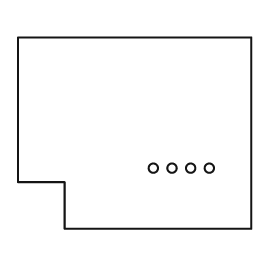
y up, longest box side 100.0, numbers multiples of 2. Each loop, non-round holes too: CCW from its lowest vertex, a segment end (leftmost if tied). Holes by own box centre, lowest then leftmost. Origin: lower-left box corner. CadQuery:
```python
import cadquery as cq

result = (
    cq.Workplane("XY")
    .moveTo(20.0, 0.0)
    .lineTo(100.0, 0.0)
    .lineTo(100.0, 82.0)
    .lineTo(0.0, 82.0)
    .lineTo(0.0, 20.0)
    .lineTo(20.0, 20.0)
    .close()
    .moveTo(58.0, 26.0)
    .circle(2.0)
    .moveTo(66.0, 26.0)
    .circle(2.0)
    .moveTo(74.0, 26.0)
    .circle(2.0)
    .moveTo(82.0, 26.0)
    .circle(2.0)
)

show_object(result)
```